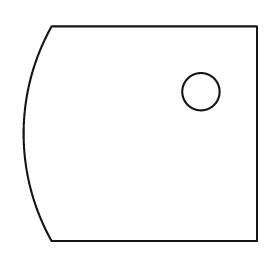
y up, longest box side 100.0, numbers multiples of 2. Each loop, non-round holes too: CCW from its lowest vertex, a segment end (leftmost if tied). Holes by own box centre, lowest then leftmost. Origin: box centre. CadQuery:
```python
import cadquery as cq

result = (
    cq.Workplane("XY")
    .moveTo(-38.0, -46.0)
    .lineTo(50.0, -46.0)
    .lineTo(50.0, 46.0)
    .lineTo(-38.0, 46.0)
    .threePointArc((-50.0, 0.0), (-38.0, -46.0))
    .close()
    .moveTo(26.0, 18.0)
    .circle(8.0)
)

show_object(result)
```